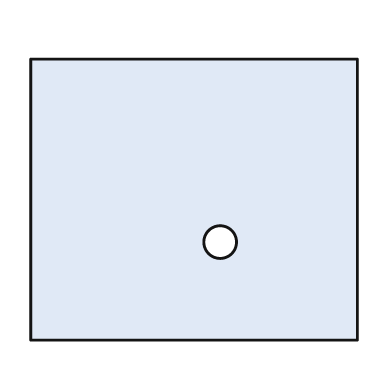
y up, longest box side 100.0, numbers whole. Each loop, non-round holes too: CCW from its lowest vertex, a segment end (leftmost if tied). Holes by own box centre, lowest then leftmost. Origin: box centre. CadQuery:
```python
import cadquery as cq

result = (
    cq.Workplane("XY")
    .moveTo(-50.0, -43.0)
    .lineTo(50.0, -43.0)
    .lineTo(50.0, 43.0)
    .lineTo(-50.0, 43.0)
    .close()
    .moveTo(8.0, -13.0)
    .circle(5.0)
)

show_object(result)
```